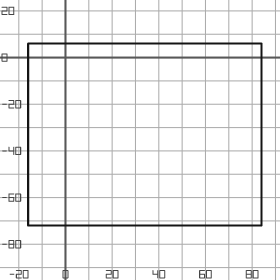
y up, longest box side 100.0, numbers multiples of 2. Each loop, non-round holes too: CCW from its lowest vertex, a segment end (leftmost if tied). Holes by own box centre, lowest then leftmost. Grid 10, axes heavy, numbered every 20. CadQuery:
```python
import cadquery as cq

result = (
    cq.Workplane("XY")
    .moveTo(-16.0, -72.0)
    .lineTo(84.0, -72.0)
    .lineTo(84.0, 6.0)
    .lineTo(-16.0, 6.0)
    .close()
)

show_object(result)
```